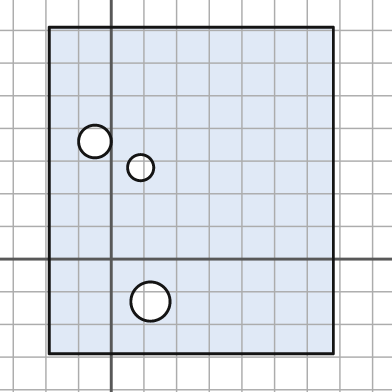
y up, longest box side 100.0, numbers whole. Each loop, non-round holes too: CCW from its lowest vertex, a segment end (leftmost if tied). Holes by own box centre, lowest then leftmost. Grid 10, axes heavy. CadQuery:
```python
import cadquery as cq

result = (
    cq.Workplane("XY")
    .moveTo(-19.0, -29.0)
    .lineTo(68.0, -29.0)
    .lineTo(68.0, 71.0)
    .lineTo(-19.0, 71.0)
    .close()
    .moveTo(12.0, -13.0)
    .circle(6.0)
    .moveTo(9.0, 28.0)
    .circle(4.0)
    .moveTo(-5.0, 36.0)
    .circle(5.0)
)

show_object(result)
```